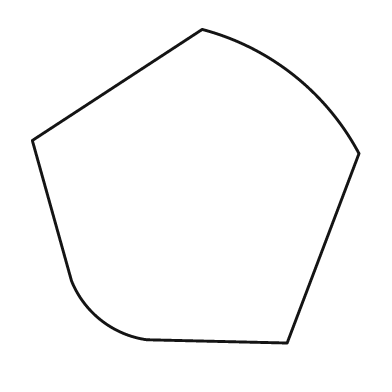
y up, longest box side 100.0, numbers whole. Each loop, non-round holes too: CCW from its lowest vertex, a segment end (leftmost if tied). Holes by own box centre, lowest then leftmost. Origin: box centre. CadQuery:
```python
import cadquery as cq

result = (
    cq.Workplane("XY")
    .moveTo(28.0, -48.0)
    .lineTo(50.0, 10.0)
    .threePointArc((30.0, 34.0), (2.0, 48.0))
    .lineTo(-50.0, 14.0)
    .lineTo(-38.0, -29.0)
    .threePointArc((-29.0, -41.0), (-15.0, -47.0))
    .close()
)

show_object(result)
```